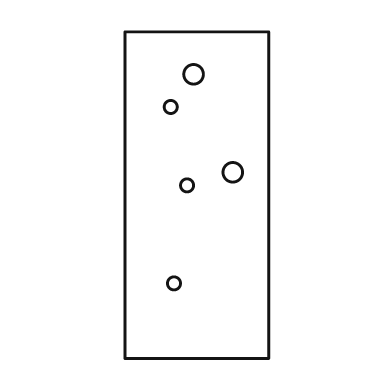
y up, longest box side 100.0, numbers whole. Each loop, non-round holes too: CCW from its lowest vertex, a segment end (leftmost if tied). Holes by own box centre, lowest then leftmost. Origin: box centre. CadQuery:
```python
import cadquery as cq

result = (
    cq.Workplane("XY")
    .moveTo(-22.0, -50.0)
    .lineTo(22.0, -50.0)
    .lineTo(22.0, 50.0)
    .lineTo(-22.0, 50.0)
    .close()
    .moveTo(-7.0, -27.0)
    .circle(2.0)
    .moveTo(-3.0, 3.0)
    .circle(2.0)
    .moveTo(11.0, 7.0)
    .circle(3.0)
    .moveTo(-8.0, 27.0)
    .circle(2.0)
    .moveTo(-1.0, 37.0)
    .circle(3.0)
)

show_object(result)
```